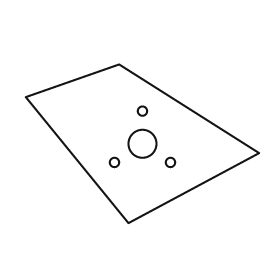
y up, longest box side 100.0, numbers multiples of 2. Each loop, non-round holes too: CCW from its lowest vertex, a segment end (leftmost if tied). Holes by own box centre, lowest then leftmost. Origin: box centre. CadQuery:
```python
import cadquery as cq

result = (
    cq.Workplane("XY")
    .moveTo(-6.0, -34.0)
    .lineTo(50.0, -4.0)
    .lineTo(-10.0, 34.0)
    .lineTo(-50.0, 20.0)
    .close()
    .moveTo(-12.0, -8.0)
    .circle(2.0)
    .moveTo(12.0, -8.0)
    .circle(2.0)
    .moveTo(0.0, 0.0)
    .circle(6.0)
    .moveTo(0.0, 14.0)
    .circle(2.0)
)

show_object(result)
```